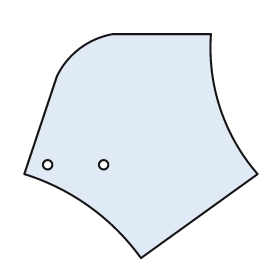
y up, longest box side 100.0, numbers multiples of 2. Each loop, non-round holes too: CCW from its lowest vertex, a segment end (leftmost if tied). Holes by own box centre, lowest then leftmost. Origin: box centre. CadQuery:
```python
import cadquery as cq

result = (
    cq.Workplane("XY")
    .moveTo(0.0, -48.0)
    .lineTo(50.0, -12.0)
    .threePointArc((34.0, 16.0), (30.0, 48.0))
    .lineTo(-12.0, 48.0)
    .threePointArc((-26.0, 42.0), (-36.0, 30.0))
    .lineTo(-50.0, -12.0)
    .threePointArc((-22.0, -26.0), (0.0, -48.0))
    .close()
    .moveTo(-40.0, -8.0)
    .circle(2.0)
    .moveTo(-16.0, -8.0)
    .circle(2.0)
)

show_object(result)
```